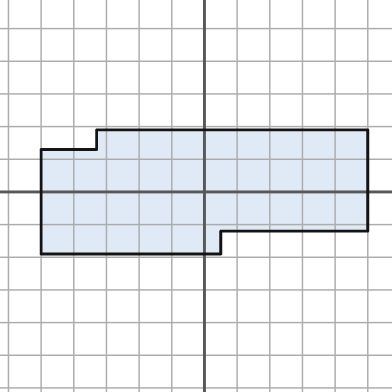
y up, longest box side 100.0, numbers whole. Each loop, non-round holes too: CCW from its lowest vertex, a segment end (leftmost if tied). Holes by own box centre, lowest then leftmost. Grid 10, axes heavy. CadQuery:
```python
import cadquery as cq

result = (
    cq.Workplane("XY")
    .moveTo(-50.0, -19.0)
    .lineTo(5.0, -19.0)
    .lineTo(5.0, -12.0)
    .lineTo(50.0, -12.0)
    .lineTo(50.0, 19.0)
    .lineTo(-33.0, 19.0)
    .lineTo(-33.0, 13.0)
    .lineTo(-50.0, 13.0)
    .close()
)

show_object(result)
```